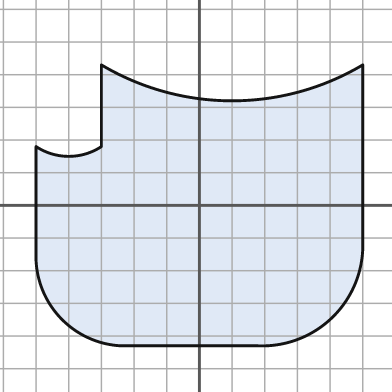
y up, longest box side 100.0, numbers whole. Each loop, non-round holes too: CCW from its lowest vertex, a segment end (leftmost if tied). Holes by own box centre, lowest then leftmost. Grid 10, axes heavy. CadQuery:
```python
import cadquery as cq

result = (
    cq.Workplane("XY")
    .moveTo(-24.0, -43.0)
    .lineTo(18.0, -43.0)
    .threePointArc((41.0, -34.0), (50.0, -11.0))
    .lineTo(50.0, 43.0)
    .threePointArc((10.0, 32.0), (-30.0, 43.0))
    .lineTo(-30.0, 18.0)
    .threePointArc((-40.0, 15.0), (-50.0, 18.0))
    .lineTo(-50.0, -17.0)
    .threePointArc((-42.0, -35.0), (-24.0, -43.0))
    .close()
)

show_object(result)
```